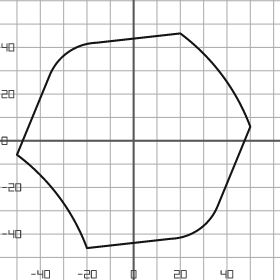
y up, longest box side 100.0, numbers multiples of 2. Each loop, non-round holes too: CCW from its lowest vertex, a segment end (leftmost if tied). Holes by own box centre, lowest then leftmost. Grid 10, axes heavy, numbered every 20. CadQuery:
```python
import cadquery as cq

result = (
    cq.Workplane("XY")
    .moveTo(-20.0, -46.0)
    .lineTo(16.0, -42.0)
    .threePointArc((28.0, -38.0), (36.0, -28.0))
    .lineTo(50.0, 6.0)
    .threePointArc((38.0, 28.0), (20.0, 46.0))
    .lineTo(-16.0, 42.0)
    .threePointArc((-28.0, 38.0), (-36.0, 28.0))
    .lineTo(-50.0, -6.0)
    .threePointArc((-32.0, -24.0), (-20.0, -46.0))
    .close()
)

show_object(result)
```